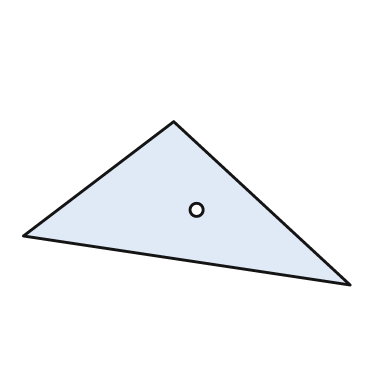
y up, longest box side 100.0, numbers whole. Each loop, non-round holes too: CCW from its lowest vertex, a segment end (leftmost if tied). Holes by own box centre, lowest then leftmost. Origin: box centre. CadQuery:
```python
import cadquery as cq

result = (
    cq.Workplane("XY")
    .moveTo(50.0, -25.0)
    .lineTo(-4.0, 25.0)
    .lineTo(-50.0, -10.0)
    .close()
    .moveTo(3.0, -2.0)
    .circle(2.0)
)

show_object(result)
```